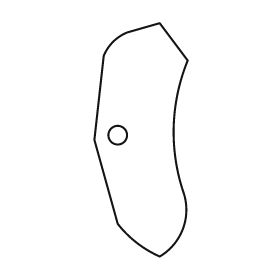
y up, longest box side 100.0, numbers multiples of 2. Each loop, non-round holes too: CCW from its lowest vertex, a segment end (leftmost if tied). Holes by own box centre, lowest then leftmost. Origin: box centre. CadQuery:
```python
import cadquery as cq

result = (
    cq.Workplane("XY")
    .moveTo(8.0, -50.0)
    .threePointArc((18.0, -38.0), (18.0, -22.0))
    .threePointArc((14.0, 6.0), (20.0, 34.0))
    .lineTo(8.0, 50.0)
    .lineTo(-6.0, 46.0)
    .threePointArc((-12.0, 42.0), (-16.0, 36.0))
    .lineTo(-20.0, 0.0)
    .lineTo(-10.0, -36.0)
    .threePointArc((-2.0, -44.0), (8.0, -50.0))
    .close()
    .moveTo(-10.0, 2.0)
    .circle(4.0)
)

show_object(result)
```